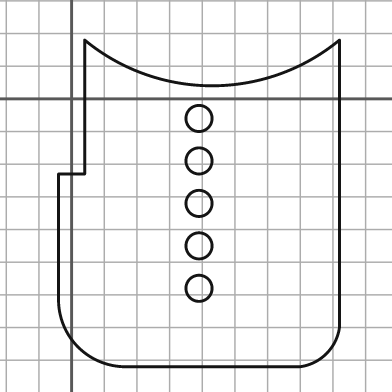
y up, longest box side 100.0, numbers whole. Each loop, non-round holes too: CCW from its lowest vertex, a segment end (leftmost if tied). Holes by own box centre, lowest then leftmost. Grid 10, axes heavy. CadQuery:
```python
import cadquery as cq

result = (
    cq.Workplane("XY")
    .moveTo(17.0, -82.0)
    .lineTo(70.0, -82.0)
    .threePointArc((78.0, -78.0), (82.0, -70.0))
    .lineTo(82.0, 18.0)
    .threePointArc((43.0, 4.0), (4.0, 18.0))
    .lineTo(4.0, -23.0)
    .lineTo(-4.0, -23.0)
    .lineTo(-4.0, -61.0)
    .threePointArc((2.0, -76.0), (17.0, -82.0))
    .close()
    .moveTo(39.0, -58.0)
    .circle(4.0)
    .moveTo(39.0, -45.0)
    .circle(4.0)
    .moveTo(39.0, -32.0)
    .circle(4.0)
    .moveTo(39.0, -19.0)
    .circle(4.0)
    .moveTo(39.0, -6.0)
    .circle(4.0)
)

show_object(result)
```